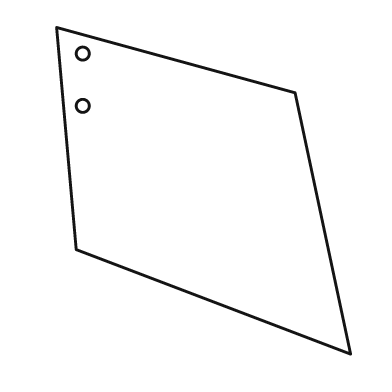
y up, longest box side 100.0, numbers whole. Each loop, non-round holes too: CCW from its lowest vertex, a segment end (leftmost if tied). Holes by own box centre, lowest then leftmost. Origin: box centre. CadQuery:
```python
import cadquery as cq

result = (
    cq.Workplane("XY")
    .moveTo(45.0, -50.0)
    .lineTo(28.0, 30.0)
    .lineTo(-45.0, 50.0)
    .lineTo(-39.0, -18.0)
    .close()
    .moveTo(-37.0, 26.0)
    .circle(2.0)
    .moveTo(-37.0, 42.0)
    .circle(2.0)
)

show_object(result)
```